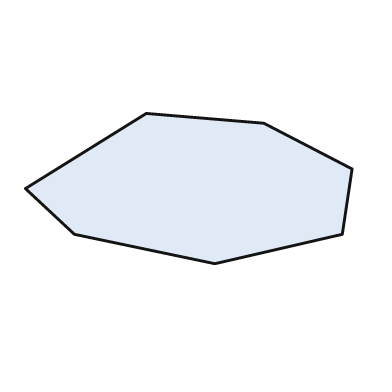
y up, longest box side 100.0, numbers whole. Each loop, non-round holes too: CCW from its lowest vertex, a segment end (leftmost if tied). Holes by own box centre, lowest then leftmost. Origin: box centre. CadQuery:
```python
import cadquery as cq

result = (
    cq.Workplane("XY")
    .moveTo(8.0, -23.0)
    .lineTo(47.0, -14.0)
    .lineTo(50.0, 6.0)
    .lineTo(23.0, 20.0)
    .lineTo(-13.0, 23.0)
    .lineTo(-50.0, 0.0)
    .lineTo(-35.0, -14.0)
    .close()
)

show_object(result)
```